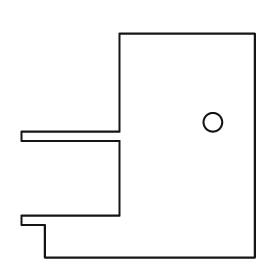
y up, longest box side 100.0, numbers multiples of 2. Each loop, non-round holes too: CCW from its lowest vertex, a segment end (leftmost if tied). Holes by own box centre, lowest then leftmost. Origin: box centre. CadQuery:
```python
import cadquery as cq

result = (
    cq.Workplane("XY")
    .moveTo(-40.0, -48.0)
    .lineTo(50.0, -48.0)
    .lineTo(50.0, 48.0)
    .lineTo(-8.0, 48.0)
    .lineTo(-8.0, 6.0)
    .lineTo(-50.0, 6.0)
    .lineTo(-50.0, 2.0)
    .lineTo(-8.0, 2.0)
    .lineTo(-8.0, -30.0)
    .lineTo(-50.0, -30.0)
    .lineTo(-50.0, -34.0)
    .lineTo(-40.0, -34.0)
    .close()
    .moveTo(32.0, 10.0)
    .circle(4.0)
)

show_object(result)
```